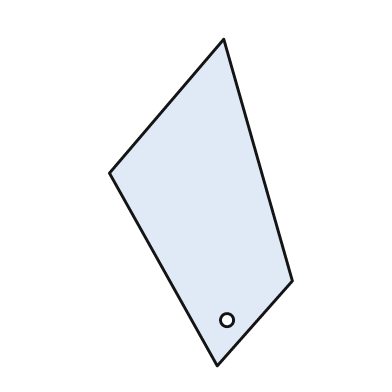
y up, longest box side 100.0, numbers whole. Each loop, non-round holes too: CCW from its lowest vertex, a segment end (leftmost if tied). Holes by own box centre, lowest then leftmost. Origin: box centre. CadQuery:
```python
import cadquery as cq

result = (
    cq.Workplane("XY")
    .moveTo(5.0, -50.0)
    .lineTo(28.0, -24.0)
    .lineTo(7.0, 50.0)
    .lineTo(-28.0, 9.0)
    .close()
    .moveTo(8.0, -36.0)
    .circle(2.0)
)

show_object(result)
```